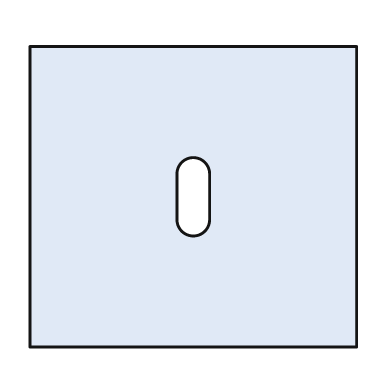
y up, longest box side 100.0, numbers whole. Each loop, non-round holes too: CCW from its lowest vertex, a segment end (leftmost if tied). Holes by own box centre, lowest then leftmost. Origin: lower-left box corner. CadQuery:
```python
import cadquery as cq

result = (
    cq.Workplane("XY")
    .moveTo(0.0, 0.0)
    .lineTo(100.0, 0.0)
    .lineTo(100.0, 92.0)
    .lineTo(0.0, 92.0)
    .close()
    .moveTo(45.0, 39.0)
    .threePointArc((50.0, 34.0), (55.0, 39.0))
    .lineTo(55.0, 53.0)
    .threePointArc((50.0, 58.0), (45.0, 53.0))
    .close()
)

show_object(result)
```